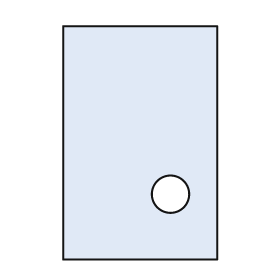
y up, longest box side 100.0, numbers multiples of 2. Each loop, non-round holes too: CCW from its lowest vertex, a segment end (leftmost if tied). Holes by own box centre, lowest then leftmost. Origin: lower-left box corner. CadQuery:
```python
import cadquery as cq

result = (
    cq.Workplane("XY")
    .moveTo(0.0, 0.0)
    .lineTo(66.0, 0.0)
    .lineTo(66.0, 100.0)
    .lineTo(0.0, 100.0)
    .close()
    .moveTo(46.0, 28.0)
    .circle(8.0)
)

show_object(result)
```